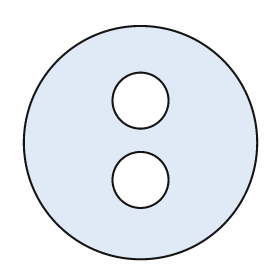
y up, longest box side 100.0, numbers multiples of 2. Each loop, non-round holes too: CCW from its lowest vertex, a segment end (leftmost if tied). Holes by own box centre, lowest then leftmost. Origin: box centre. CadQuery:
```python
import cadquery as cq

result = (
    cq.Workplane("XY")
    .moveTo(0.0, 0.0)
    .circle(50.0)
    .moveTo(0.0, -16.0)
    .circle(12.0)
    .moveTo(0.0, 18.0)
    .circle(12.0)
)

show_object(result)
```